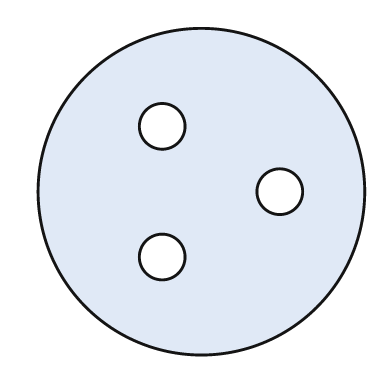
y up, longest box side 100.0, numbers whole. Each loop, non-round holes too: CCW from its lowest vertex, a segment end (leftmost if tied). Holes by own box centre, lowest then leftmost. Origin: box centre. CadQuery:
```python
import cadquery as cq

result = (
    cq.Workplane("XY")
    .moveTo(0.0, 0.0)
    .circle(50.0)
    .moveTo(-12.0, -20.0)
    .circle(7.0)
    .moveTo(24.0, 0.0)
    .circle(7.0)
    .moveTo(-12.0, 20.0)
    .circle(7.0)
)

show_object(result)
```